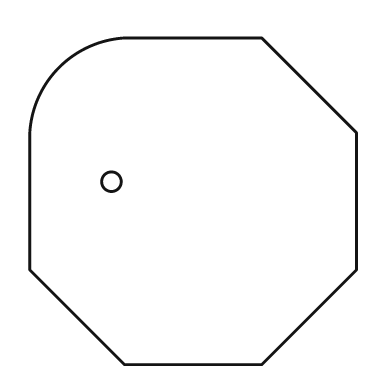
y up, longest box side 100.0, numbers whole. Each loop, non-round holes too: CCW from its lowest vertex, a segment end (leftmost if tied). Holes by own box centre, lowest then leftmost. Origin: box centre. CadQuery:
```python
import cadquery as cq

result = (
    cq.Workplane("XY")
    .moveTo(-21.0, -50.0)
    .lineTo(21.0, -50.0)
    .lineTo(50.0, -21.0)
    .lineTo(50.0, 21.0)
    .lineTo(21.0, 50.0)
    .lineTo(-21.0, 50.0)
    .threePointArc((-41.0, 41.0), (-50.0, 21.0))
    .lineTo(-50.0, -21.0)
    .close()
    .moveTo(-25.0, 6.0)
    .circle(3.0)
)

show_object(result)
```